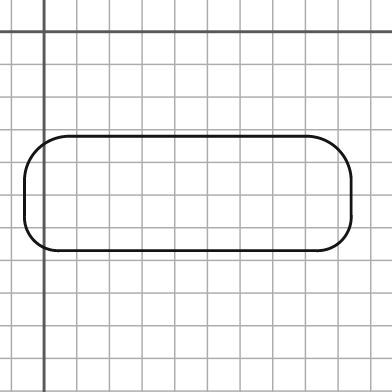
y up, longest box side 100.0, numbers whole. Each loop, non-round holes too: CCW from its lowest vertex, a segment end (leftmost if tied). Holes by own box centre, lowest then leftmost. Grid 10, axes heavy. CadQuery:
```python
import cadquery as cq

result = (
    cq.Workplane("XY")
    .moveTo(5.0, -67.0)
    .lineTo(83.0, -67.0)
    .threePointArc((91.0, -64.0), (94.0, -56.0))
    .lineTo(94.0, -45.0)
    .threePointArc((90.0, -36.0), (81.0, -32.0))
    .lineTo(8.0, -32.0)
    .threePointArc((-2.0, -36.0), (-6.0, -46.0))
    .lineTo(-6.0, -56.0)
    .threePointArc((-3.0, -64.0), (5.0, -67.0))
    .close()
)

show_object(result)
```